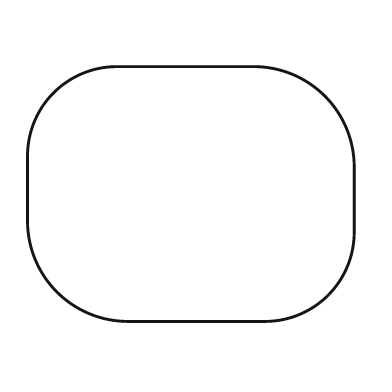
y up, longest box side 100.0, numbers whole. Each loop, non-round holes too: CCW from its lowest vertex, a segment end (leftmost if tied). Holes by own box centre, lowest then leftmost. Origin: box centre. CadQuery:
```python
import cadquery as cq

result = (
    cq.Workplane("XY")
    .moveTo(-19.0, -39.0)
    .lineTo(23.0, -39.0)
    .threePointArc((42.0, -31.0), (50.0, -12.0))
    .lineTo(50.0, 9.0)
    .threePointArc((41.0, 30.0), (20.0, 39.0))
    .lineTo(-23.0, 39.0)
    .threePointArc((-42.0, 31.0), (-50.0, 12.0))
    .lineTo(-50.0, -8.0)
    .threePointArc((-41.0, -30.0), (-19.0, -39.0))
    .close()
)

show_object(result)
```